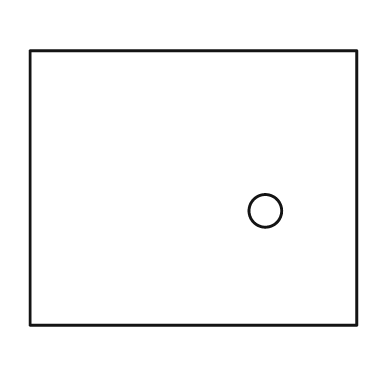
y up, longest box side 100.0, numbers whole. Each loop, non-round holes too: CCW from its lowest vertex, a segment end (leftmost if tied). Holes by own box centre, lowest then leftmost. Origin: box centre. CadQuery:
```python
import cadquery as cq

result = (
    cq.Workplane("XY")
    .moveTo(-50.0, -42.0)
    .lineTo(50.0, -42.0)
    .lineTo(50.0, 42.0)
    .lineTo(-50.0, 42.0)
    .close()
    .moveTo(22.0, -7.0)
    .circle(5.0)
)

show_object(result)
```